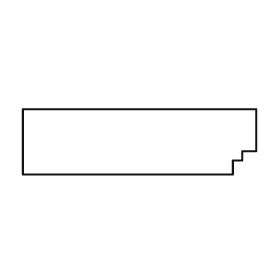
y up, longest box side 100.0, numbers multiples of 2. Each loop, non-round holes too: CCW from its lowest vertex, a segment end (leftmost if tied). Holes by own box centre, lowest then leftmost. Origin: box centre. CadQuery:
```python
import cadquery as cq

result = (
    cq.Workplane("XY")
    .moveTo(-50.0, -14.0)
    .lineTo(40.0, -14.0)
    .lineTo(40.0, -8.0)
    .lineTo(44.0, -8.0)
    .lineTo(44.0, -4.0)
    .lineTo(50.0, -4.0)
    .lineTo(50.0, 14.0)
    .lineTo(-50.0, 14.0)
    .close()
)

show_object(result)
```